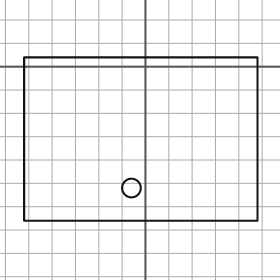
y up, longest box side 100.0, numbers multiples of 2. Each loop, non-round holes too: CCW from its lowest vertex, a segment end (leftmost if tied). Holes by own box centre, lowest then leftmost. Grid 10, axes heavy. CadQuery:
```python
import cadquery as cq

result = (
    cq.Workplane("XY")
    .moveTo(-52.0, -66.0)
    .lineTo(48.0, -66.0)
    .lineTo(48.0, 4.0)
    .lineTo(-52.0, 4.0)
    .close()
    .moveTo(-6.0, -52.0)
    .circle(4.0)
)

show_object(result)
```